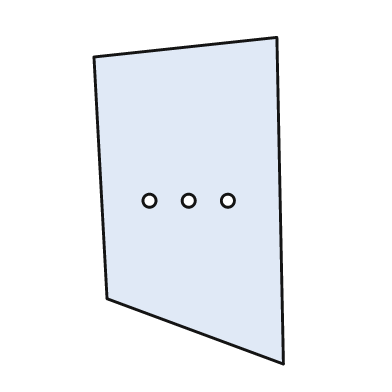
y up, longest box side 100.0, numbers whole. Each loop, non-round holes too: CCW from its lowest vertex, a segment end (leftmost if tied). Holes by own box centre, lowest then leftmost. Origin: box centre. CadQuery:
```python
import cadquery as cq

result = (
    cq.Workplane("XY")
    .moveTo(29.0, -50.0)
    .lineTo(27.0, 50.0)
    .lineTo(-29.0, 44.0)
    .lineTo(-25.0, -30.0)
    .close()
    .moveTo(-12.0, 0.0)
    .circle(2.0)
    .moveTo(0.0, 0.0)
    .circle(2.0)
    .moveTo(12.0, 0.0)
    .circle(2.0)
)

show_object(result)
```